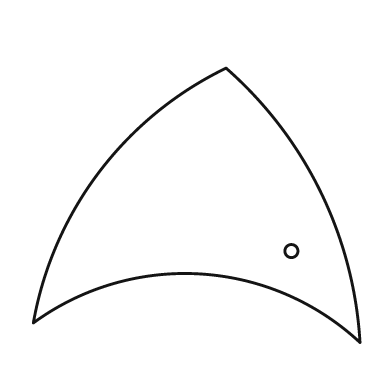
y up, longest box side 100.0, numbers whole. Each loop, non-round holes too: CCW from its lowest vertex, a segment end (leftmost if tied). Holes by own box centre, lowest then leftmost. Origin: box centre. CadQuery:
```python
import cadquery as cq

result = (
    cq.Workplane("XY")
    .moveTo(50.0, -42.0)
    .threePointArc((38.0, 4.0), (9.0, 42.0))
    .threePointArc((-30.0, 10.0), (-50.0, -36.0))
    .threePointArc((1.0, -21.0), (50.0, -42.0))
    .close()
    .moveTo(29.0, -14.0)
    .circle(2.0)
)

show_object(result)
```